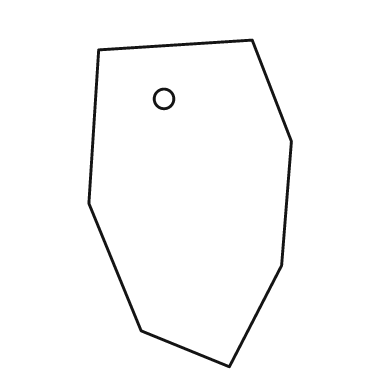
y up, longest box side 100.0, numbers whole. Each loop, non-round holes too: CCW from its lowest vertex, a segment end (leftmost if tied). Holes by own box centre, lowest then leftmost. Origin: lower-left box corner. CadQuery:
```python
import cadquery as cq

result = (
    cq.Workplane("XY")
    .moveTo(43.0, 0.0)
    .lineTo(59.0, 31.0)
    .lineTo(62.0, 69.0)
    .lineTo(50.0, 100.0)
    .lineTo(3.0, 97.0)
    .lineTo(0.0, 50.0)
    .lineTo(16.0, 11.0)
    .close()
    .moveTo(23.0, 82.0)
    .circle(3.0)
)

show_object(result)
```